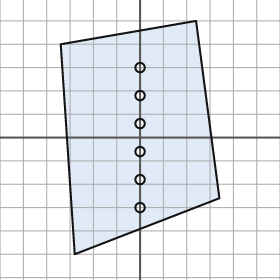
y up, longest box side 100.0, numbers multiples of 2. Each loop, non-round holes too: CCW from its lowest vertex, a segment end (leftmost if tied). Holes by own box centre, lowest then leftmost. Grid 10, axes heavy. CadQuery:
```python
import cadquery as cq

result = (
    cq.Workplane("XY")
    .moveTo(-28.0, -50.0)
    .lineTo(34.0, -26.0)
    .lineTo(24.0, 50.0)
    .lineTo(-34.0, 40.0)
    .close()
    .moveTo(0.0, -30.0)
    .circle(2.0)
    .moveTo(0.0, -18.0)
    .circle(2.0)
    .moveTo(0.0, -6.0)
    .circle(2.0)
    .moveTo(0.0, 6.0)
    .circle(2.0)
    .moveTo(0.0, 18.0)
    .circle(2.0)
    .moveTo(0.0, 30.0)
    .circle(2.0)
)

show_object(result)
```